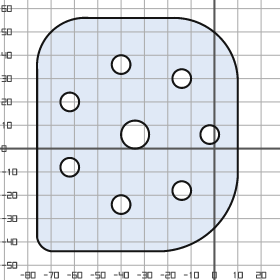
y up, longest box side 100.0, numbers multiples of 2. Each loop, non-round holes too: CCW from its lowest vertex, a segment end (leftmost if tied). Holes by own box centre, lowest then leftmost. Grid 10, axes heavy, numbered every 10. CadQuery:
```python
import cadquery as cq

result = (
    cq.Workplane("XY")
    .moveTo(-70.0, -44.0)
    .lineTo(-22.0, -44.0)
    .threePointArc((0.0, -34.0), (10.0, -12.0))
    .lineTo(10.0, 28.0)
    .threePointArc((2.0, 48.0), (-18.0, 56.0))
    .lineTo(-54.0, 56.0)
    .threePointArc((-70.0, 50.0), (-76.0, 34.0))
    .lineTo(-76.0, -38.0)
    .threePointArc((-74.0, -42.0), (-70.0, -44.0))
    .close()
    .moveTo(-40.0, -24.0)
    .circle(4.0)
    .moveTo(-14.0, -18.0)
    .circle(4.0)
    .moveTo(-62.0, -8.0)
    .circle(4.0)
    .moveTo(-34.0, 6.0)
    .circle(6.0)
    .moveTo(-2.0, 6.0)
    .circle(4.0)
    .moveTo(-62.0, 20.0)
    .circle(4.0)
    .moveTo(-14.0, 30.0)
    .circle(4.0)
    .moveTo(-40.0, 36.0)
    .circle(4.0)
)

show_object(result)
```